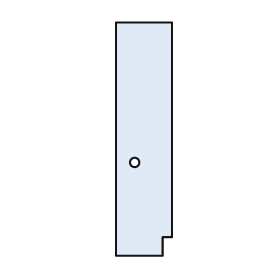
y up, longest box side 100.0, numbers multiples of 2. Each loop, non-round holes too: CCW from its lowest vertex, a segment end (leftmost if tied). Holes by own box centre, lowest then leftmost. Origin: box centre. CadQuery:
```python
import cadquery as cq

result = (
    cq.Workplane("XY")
    .moveTo(-12.0, -50.0)
    .lineTo(8.0, -50.0)
    .lineTo(8.0, -42.0)
    .lineTo(12.0, -42.0)
    .lineTo(12.0, 50.0)
    .lineTo(-12.0, 50.0)
    .close()
    .moveTo(-4.0, -10.0)
    .circle(2.0)
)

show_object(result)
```